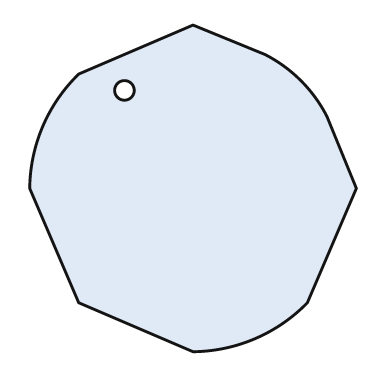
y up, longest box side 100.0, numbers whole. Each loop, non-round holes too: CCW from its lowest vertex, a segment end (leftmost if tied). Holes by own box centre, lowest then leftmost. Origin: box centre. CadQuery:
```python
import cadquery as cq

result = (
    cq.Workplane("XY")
    .moveTo(0.0, -50.0)
    .threePointArc((19.0, -46.0), (35.0, -35.0))
    .lineTo(50.0, 0.0)
    .lineTo(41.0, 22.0)
    .threePointArc((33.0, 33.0), (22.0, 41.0))
    .lineTo(0.0, 50.0)
    .lineTo(-35.0, 35.0)
    .threePointArc((-46.0, 19.0), (-50.0, 0.0))
    .lineTo(-35.0, -35.0)
    .close()
    .moveTo(-21.0, 30.0)
    .circle(3.0)
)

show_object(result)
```